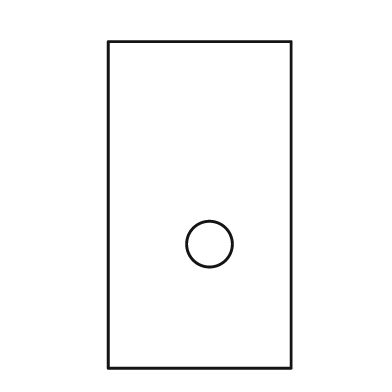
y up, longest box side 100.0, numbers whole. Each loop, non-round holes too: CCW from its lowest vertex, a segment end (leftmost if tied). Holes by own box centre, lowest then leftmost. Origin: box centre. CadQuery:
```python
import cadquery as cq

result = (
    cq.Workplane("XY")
    .moveTo(-28.0, -50.0)
    .lineTo(28.0, -50.0)
    .lineTo(28.0, 50.0)
    .lineTo(-28.0, 50.0)
    .close()
    .moveTo(3.0, -12.0)
    .circle(7.0)
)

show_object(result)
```